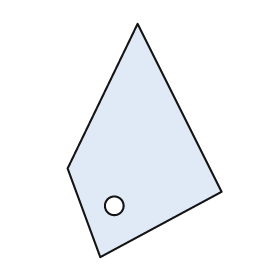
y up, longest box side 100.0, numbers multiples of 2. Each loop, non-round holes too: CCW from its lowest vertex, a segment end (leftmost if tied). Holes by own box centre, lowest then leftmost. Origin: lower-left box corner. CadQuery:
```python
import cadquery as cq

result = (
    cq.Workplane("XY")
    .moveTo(14.0, 0.0)
    .lineTo(66.0, 28.0)
    .lineTo(30.0, 100.0)
    .lineTo(0.0, 38.0)
    .close()
    .moveTo(20.0, 22.0)
    .circle(4.0)
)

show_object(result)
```